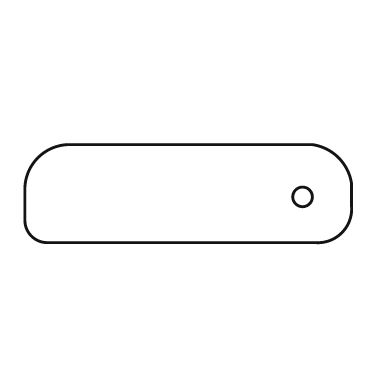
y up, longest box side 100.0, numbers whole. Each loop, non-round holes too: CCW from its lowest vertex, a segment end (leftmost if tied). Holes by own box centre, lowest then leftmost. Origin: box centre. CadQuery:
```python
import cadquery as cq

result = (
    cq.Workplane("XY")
    .moveTo(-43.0, -15.0)
    .lineTo(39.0, -15.0)
    .threePointArc((47.0, -12.0), (50.0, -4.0))
    .lineTo(50.0, 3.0)
    .threePointArc((46.0, 11.0), (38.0, 15.0))
    .lineTo(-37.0, 15.0)
    .threePointArc((-46.0, 11.0), (-50.0, 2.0))
    .lineTo(-50.0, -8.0)
    .threePointArc((-48.0, -13.0), (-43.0, -15.0))
    .close()
    .moveTo(35.0, -1.0)
    .circle(3.0)
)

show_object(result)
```